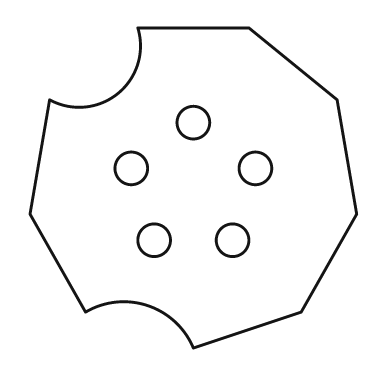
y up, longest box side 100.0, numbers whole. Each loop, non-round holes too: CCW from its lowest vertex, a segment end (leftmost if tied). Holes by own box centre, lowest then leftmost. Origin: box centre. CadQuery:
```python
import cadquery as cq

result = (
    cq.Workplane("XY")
    .moveTo(0.0, -49.0)
    .lineTo(33.0, -38.0)
    .lineTo(50.0, -8.0)
    .lineTo(44.0, 27.0)
    .lineTo(17.0, 49.0)
    .lineTo(-17.0, 49.0)
    .threePointArc((-23.0, 29.0), (-44.0, 27.0))
    .lineTo(-50.0, -8.0)
    .lineTo(-33.0, -38.0)
    .threePointArc((-14.0, -36.0), (0.0, -49.0))
    .close()
    .moveTo(-12.0, -16.0)
    .circle(5.0)
    .moveTo(12.0, -16.0)
    .circle(5.0)
    .moveTo(-19.0, 6.0)
    .circle(5.0)
    .moveTo(19.0, 6.0)
    .circle(5.0)
    .moveTo(0.0, 20.0)
    .circle(5.0)
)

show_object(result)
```